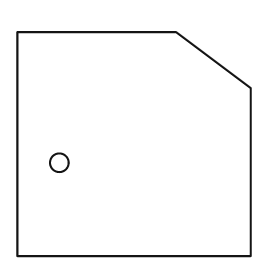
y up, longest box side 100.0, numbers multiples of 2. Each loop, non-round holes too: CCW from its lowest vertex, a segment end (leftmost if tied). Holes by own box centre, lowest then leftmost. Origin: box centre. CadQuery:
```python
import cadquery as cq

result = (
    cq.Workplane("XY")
    .moveTo(-50.0, -48.0)
    .lineTo(50.0, -48.0)
    .lineTo(50.0, 24.0)
    .lineTo(18.0, 48.0)
    .lineTo(-50.0, 48.0)
    .close()
    .moveTo(-32.0, -8.0)
    .circle(4.0)
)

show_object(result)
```